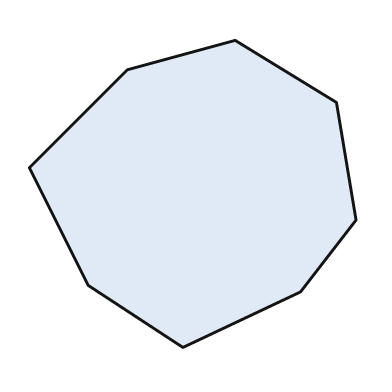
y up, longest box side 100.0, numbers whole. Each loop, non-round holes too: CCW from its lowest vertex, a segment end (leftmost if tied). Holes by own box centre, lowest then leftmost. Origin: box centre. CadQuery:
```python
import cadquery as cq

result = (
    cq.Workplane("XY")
    .moveTo(-3.0, -47.0)
    .lineTo(33.0, -30.0)
    .lineTo(50.0, -8.0)
    .lineTo(44.0, 28.0)
    .lineTo(13.0, 47.0)
    .lineTo(-20.0, 38.0)
    .lineTo(-50.0, 8.0)
    .lineTo(-32.0, -28.0)
    .close()
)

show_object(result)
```